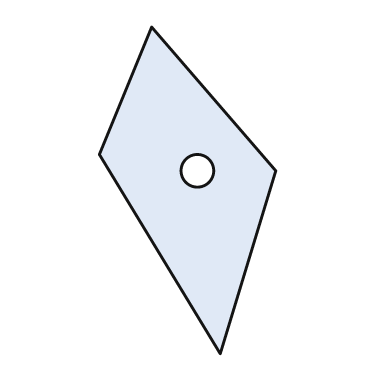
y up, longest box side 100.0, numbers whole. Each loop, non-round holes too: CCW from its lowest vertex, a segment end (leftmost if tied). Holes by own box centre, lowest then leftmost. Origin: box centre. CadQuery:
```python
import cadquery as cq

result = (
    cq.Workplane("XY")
    .moveTo(10.0, -50.0)
    .lineTo(27.0, 6.0)
    .lineTo(-11.0, 50.0)
    .lineTo(-27.0, 11.0)
    .close()
    .moveTo(3.0, 6.0)
    .circle(5.0)
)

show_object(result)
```